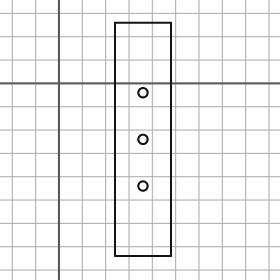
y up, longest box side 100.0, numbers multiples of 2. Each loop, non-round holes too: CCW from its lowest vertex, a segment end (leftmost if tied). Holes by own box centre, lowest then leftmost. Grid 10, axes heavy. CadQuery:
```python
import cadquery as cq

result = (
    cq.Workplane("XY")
    .moveTo(24.0, -74.0)
    .lineTo(48.0, -74.0)
    .lineTo(48.0, 26.0)
    .lineTo(24.0, 26.0)
    .close()
    .moveTo(36.0, -44.0)
    .circle(2.0)
    .moveTo(36.0, -24.0)
    .circle(2.0)
    .moveTo(36.0, -4.0)
    .circle(2.0)
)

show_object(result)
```